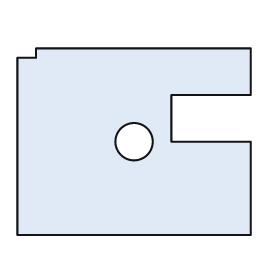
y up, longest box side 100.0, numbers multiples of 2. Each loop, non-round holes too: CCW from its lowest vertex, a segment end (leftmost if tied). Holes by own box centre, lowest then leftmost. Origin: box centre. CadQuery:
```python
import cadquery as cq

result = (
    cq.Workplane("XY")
    .moveTo(-50.0, -40.0)
    .lineTo(50.0, -40.0)
    .lineTo(50.0, 0.0)
    .lineTo(16.0, 0.0)
    .lineTo(16.0, 20.0)
    .lineTo(50.0, 20.0)
    .lineTo(50.0, 40.0)
    .lineTo(-42.0, 40.0)
    .lineTo(-42.0, 36.0)
    .lineTo(-50.0, 36.0)
    .close()
    .moveTo(0.0, 0.0)
    .circle(8.0)
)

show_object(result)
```